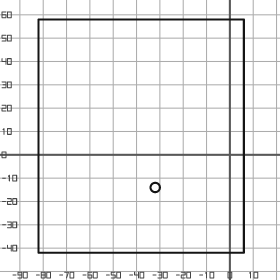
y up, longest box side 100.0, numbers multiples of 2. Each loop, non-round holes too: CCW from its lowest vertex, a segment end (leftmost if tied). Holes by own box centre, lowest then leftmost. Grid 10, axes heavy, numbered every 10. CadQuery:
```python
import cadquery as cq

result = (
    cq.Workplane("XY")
    .moveTo(-82.0, -42.0)
    .lineTo(6.0, -42.0)
    .lineTo(6.0, 58.0)
    .lineTo(-82.0, 58.0)
    .close()
    .moveTo(-32.0, -14.0)
    .circle(2.0)
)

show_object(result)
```